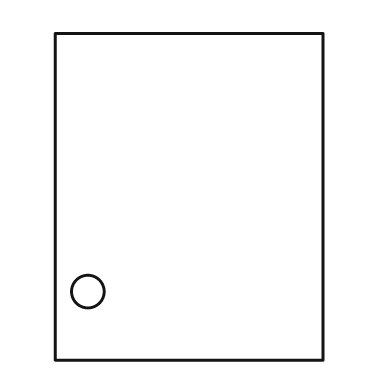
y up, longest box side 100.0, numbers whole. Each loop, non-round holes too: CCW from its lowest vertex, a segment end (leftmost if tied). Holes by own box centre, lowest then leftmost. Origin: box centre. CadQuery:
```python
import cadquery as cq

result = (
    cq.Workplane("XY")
    .moveTo(-41.0, -50.0)
    .lineTo(41.0, -50.0)
    .lineTo(41.0, 50.0)
    .lineTo(-41.0, 50.0)
    .close()
    .moveTo(-31.0, -29.0)
    .circle(5.0)
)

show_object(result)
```